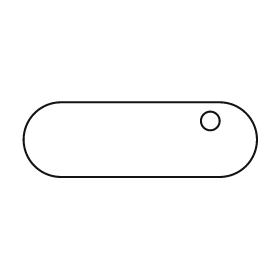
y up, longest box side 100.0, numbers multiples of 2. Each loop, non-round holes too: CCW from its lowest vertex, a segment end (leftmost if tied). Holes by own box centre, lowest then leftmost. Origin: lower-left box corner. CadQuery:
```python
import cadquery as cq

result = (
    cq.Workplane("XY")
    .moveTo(16.0, 0.0)
    .lineTo(84.0, 0.0)
    .threePointArc((100.0, 16.0), (84.0, 32.0))
    .lineTo(16.0, 32.0)
    .threePointArc((0.0, 16.0), (16.0, 0.0))
    .close()
    .moveTo(80.0, 24.0)
    .circle(4.0)
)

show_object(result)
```